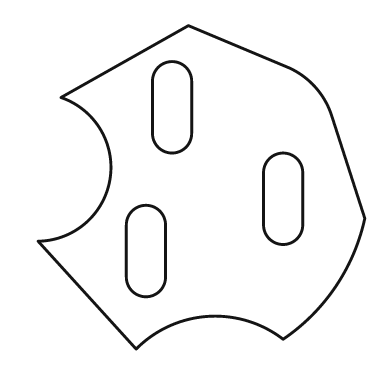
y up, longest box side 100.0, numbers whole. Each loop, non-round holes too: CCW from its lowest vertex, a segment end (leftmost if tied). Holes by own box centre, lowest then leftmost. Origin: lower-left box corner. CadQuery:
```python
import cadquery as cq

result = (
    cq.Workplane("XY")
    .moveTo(30.0, 0.0)
    .threePointArc((52.0, 10.0), (75.0, 3.0))
    .threePointArc((91.0, 19.0), (100.0, 40.0))
    .lineTo(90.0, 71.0)
    .threePointArc((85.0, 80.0), (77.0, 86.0))
    .lineTo(46.0, 99.0)
    .lineTo(7.0, 77.0)
    .threePointArc((22.0, 52.0), (0.0, 33.0))
    .close()
    .moveTo(27.0, 22.0)
    .threePointArc((33.0, 16.0), (39.0, 22.0))
    .lineTo(39.0, 38.0)
    .threePointArc((33.0, 44.0), (27.0, 38.0))
    .close()
    .moveTo(69.0, 38.0)
    .threePointArc((75.0, 32.0), (81.0, 38.0))
    .lineTo(81.0, 54.0)
    .threePointArc((75.0, 60.0), (69.0, 54.0))
    .close()
    .moveTo(35.0, 66.0)
    .threePointArc((41.0, 60.0), (47.0, 66.0))
    .lineTo(47.0, 82.0)
    .threePointArc((41.0, 88.0), (35.0, 82.0))
    .close()
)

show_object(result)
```